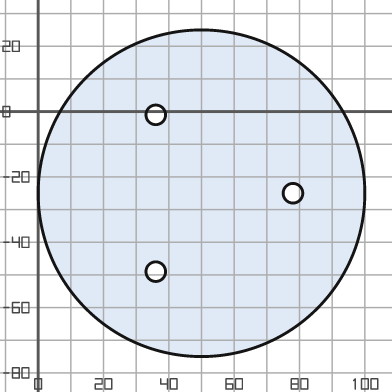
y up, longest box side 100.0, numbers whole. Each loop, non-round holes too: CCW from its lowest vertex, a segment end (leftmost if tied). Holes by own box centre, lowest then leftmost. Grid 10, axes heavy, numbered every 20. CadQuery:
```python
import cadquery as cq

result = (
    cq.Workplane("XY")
    .moveTo(50.0, -25.0)
    .circle(50.0)
    .moveTo(36.0, -49.0)
    .circle(3.0)
    .moveTo(78.0, -25.0)
    .circle(3.0)
    .moveTo(36.0, -1.0)
    .circle(3.0)
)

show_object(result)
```